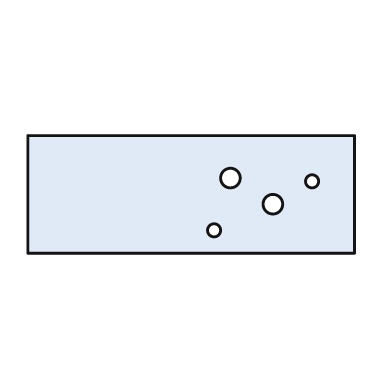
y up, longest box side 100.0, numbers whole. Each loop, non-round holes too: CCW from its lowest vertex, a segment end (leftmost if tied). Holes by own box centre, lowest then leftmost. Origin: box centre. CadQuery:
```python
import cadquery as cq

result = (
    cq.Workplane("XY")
    .moveTo(-50.0, -18.0)
    .lineTo(50.0, -18.0)
    .lineTo(50.0, 18.0)
    .lineTo(-50.0, 18.0)
    .close()
    .moveTo(7.0, -11.0)
    .circle(2.0)
    .moveTo(25.0, -3.0)
    .circle(3.0)
    .moveTo(37.0, 4.0)
    .circle(2.0)
    .moveTo(12.0, 5.0)
    .circle(3.0)
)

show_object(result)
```